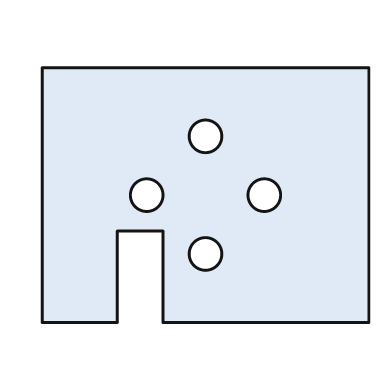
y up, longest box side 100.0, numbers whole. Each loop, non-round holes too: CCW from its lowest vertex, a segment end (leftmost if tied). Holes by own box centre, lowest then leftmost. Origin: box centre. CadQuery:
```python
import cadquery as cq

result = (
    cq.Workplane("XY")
    .moveTo(-50.0, -39.0)
    .lineTo(-27.0, -39.0)
    .lineTo(-27.0, -11.0)
    .lineTo(-13.0, -11.0)
    .lineTo(-13.0, -39.0)
    .lineTo(50.0, -39.0)
    .lineTo(50.0, 39.0)
    .lineTo(-50.0, 39.0)
    .close()
    .moveTo(0.0, -18.0)
    .circle(5.0)
    .moveTo(-18.0, 0.0)
    .circle(5.0)
    .moveTo(18.0, 0.0)
    .circle(5.0)
    .moveTo(0.0, 18.0)
    .circle(5.0)
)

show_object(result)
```